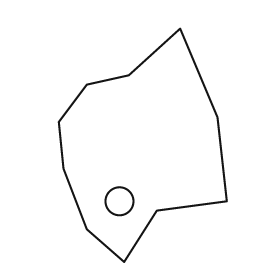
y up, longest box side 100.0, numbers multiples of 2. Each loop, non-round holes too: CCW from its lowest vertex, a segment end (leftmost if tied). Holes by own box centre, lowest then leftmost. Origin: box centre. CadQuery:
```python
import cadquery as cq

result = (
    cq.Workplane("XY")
    .moveTo(-8.0, -50.0)
    .lineTo(6.0, -28.0)
    .lineTo(36.0, -24.0)
    .lineTo(32.0, 12.0)
    .lineTo(16.0, 50.0)
    .lineTo(-6.0, 30.0)
    .lineTo(-24.0, 26.0)
    .lineTo(-36.0, 10.0)
    .lineTo(-34.0, -10.0)
    .lineTo(-24.0, -36.0)
    .close()
    .moveTo(-10.0, -24.0)
    .circle(6.0)
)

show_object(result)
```